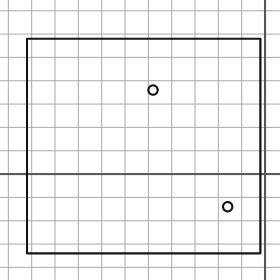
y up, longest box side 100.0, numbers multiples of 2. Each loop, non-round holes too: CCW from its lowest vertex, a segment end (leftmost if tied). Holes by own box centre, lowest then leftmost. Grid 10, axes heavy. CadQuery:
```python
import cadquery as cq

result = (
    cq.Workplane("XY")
    .moveTo(-102.0, -34.0)
    .lineTo(-2.0, -34.0)
    .lineTo(-2.0, 58.0)
    .lineTo(-102.0, 58.0)
    .close()
    .moveTo(-16.0, -14.0)
    .circle(2.0)
    .moveTo(-48.0, 36.0)
    .circle(2.0)
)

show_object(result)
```